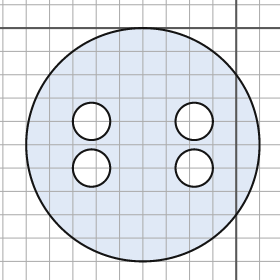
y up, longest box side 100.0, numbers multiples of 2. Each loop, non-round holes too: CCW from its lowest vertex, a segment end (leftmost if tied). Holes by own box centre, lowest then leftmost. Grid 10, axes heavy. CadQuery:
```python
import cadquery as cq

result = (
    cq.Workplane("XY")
    .moveTo(-40.0, -50.0)
    .circle(50.0)
    .moveTo(-62.0, -60.0)
    .circle(8.0)
    .moveTo(-18.0, -60.0)
    .circle(8.0)
    .moveTo(-62.0, -40.0)
    .circle(8.0)
    .moveTo(-18.0, -40.0)
    .circle(8.0)
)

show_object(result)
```